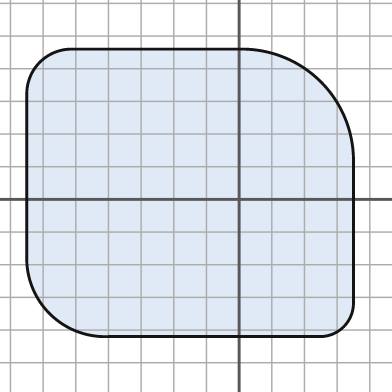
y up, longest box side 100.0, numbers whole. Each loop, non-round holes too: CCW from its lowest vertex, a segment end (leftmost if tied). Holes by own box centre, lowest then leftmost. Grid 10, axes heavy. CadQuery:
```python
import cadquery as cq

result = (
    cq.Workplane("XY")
    .moveTo(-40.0, -42.0)
    .lineTo(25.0, -42.0)
    .threePointArc((32.0, -39.0), (35.0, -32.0))
    .lineTo(35.0, 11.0)
    .threePointArc((25.0, 36.0), (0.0, 46.0))
    .lineTo(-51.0, 46.0)
    .threePointArc((-61.0, 42.0), (-65.0, 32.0))
    .lineTo(-65.0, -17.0)
    .threePointArc((-58.0, -35.0), (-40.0, -42.0))
    .close()
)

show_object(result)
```